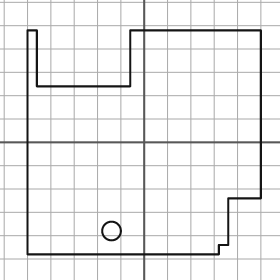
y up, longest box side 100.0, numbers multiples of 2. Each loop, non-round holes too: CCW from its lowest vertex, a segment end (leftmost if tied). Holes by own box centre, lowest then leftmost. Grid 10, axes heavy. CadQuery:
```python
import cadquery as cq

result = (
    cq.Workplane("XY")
    .moveTo(-50.0, -48.0)
    .lineTo(32.0, -48.0)
    .lineTo(32.0, -44.0)
    .lineTo(36.0, -44.0)
    .lineTo(36.0, -24.0)
    .lineTo(50.0, -24.0)
    .lineTo(50.0, 48.0)
    .lineTo(-6.0, 48.0)
    .lineTo(-6.0, 24.0)
    .lineTo(-46.0, 24.0)
    .lineTo(-46.0, 48.0)
    .lineTo(-50.0, 48.0)
    .close()
    .moveTo(-14.0, -38.0)
    .circle(4.0)
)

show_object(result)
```